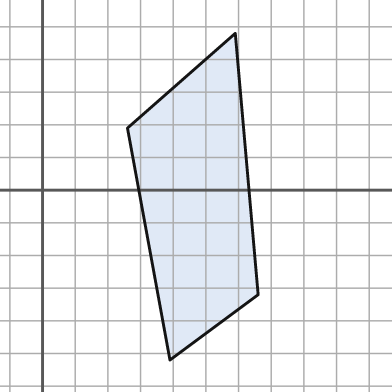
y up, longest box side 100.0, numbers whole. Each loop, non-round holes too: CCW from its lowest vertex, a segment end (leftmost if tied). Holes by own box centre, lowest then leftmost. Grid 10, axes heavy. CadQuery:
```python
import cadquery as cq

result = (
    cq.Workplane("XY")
    .moveTo(39.0, -52.0)
    .lineTo(66.0, -32.0)
    .lineTo(59.0, 48.0)
    .lineTo(26.0, 19.0)
    .close()
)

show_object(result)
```